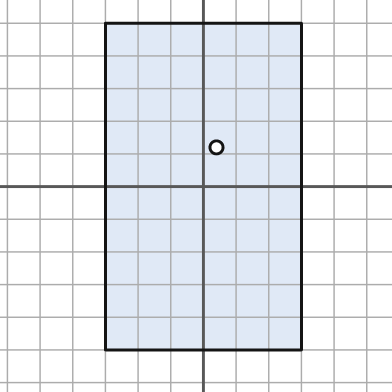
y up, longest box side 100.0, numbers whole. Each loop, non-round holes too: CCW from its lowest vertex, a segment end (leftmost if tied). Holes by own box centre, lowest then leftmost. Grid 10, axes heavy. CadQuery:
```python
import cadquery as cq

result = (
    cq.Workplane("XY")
    .moveTo(-30.0, -50.0)
    .lineTo(30.0, -50.0)
    .lineTo(30.0, 50.0)
    .lineTo(-30.0, 50.0)
    .close()
    .moveTo(4.0, 12.0)
    .circle(2.0)
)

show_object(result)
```